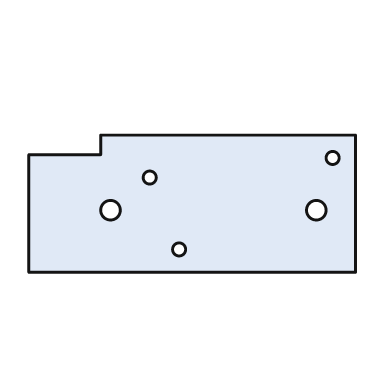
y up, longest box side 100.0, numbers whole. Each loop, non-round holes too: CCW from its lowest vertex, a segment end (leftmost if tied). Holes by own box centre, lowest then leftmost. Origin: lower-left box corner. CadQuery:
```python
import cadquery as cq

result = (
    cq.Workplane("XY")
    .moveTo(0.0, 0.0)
    .lineTo(100.0, 0.0)
    .lineTo(100.0, 42.0)
    .lineTo(22.0, 42.0)
    .lineTo(22.0, 36.0)
    .lineTo(0.0, 36.0)
    .close()
    .moveTo(46.0, 7.0)
    .circle(2.0)
    .moveTo(25.0, 19.0)
    .circle(3.0)
    .moveTo(88.0, 19.0)
    .circle(3.0)
    .moveTo(37.0, 29.0)
    .circle(2.0)
    .moveTo(93.0, 35.0)
    .circle(2.0)
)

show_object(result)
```